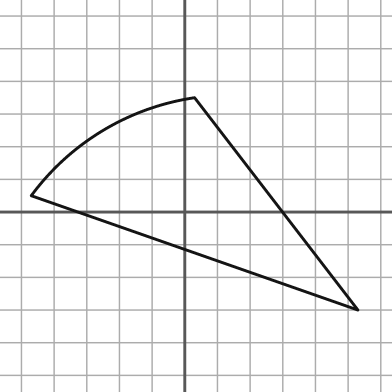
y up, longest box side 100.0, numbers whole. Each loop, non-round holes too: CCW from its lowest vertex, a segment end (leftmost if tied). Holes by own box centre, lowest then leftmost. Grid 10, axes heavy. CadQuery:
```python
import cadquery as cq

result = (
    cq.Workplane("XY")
    .moveTo(53.0, -30.0)
    .lineTo(3.0, 35.0)
    .threePointArc((-25.0, 25.0), (-47.0, 5.0))
    .close()
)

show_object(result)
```